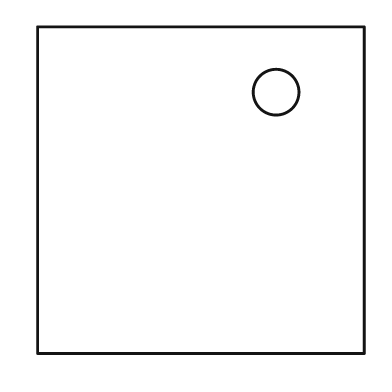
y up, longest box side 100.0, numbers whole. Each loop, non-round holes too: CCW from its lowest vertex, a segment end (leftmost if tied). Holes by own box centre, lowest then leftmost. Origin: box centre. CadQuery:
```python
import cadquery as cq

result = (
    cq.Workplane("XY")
    .moveTo(-50.0, -50.0)
    .lineTo(50.0, -50.0)
    .lineTo(50.0, 50.0)
    .lineTo(-50.0, 50.0)
    .close()
    .moveTo(23.0, 30.0)
    .circle(7.0)
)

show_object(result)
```